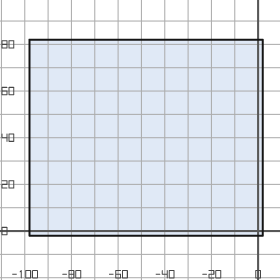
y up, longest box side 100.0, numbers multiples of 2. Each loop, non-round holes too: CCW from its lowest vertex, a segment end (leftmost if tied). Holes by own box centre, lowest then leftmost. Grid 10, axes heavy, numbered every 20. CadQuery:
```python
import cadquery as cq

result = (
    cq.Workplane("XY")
    .moveTo(-98.0, -2.0)
    .lineTo(2.0, -2.0)
    .lineTo(2.0, 82.0)
    .lineTo(-98.0, 82.0)
    .close()
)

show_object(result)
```